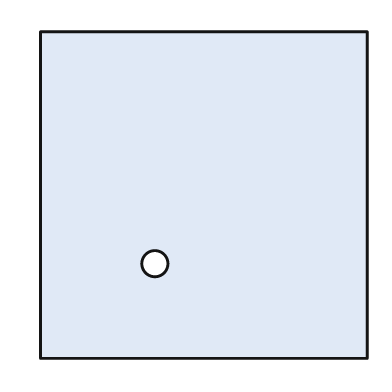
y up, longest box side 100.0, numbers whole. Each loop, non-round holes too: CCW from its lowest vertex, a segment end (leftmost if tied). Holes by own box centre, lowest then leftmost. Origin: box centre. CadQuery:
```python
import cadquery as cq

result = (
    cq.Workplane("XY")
    .moveTo(-50.0, -50.0)
    .lineTo(50.0, -50.0)
    .lineTo(50.0, 50.0)
    .lineTo(-50.0, 50.0)
    .close()
    .moveTo(-15.0, -21.0)
    .circle(4.0)
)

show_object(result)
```